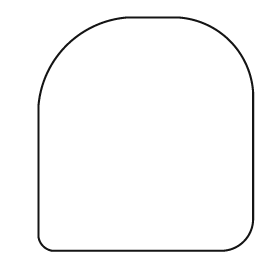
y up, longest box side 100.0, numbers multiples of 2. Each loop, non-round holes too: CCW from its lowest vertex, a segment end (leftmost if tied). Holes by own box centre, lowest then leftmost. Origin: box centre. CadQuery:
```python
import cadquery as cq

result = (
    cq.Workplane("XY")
    .moveTo(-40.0, -50.0)
    .lineTo(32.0, -50.0)
    .threePointArc((42.0, -46.0), (46.0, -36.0))
    .lineTo(46.0, 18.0)
    .threePointArc((36.0, 40.0), (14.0, 50.0))
    .lineTo(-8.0, 50.0)
    .threePointArc((-34.0, 38.0), (-46.0, 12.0))
    .lineTo(-46.0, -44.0)
    .threePointArc((-44.0, -48.0), (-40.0, -50.0))
    .close()
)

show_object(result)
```